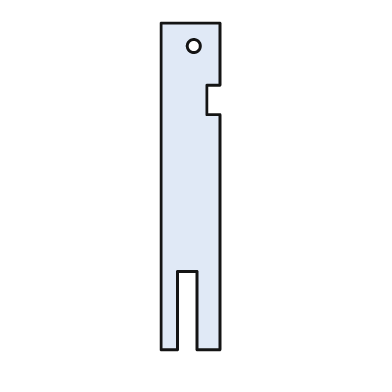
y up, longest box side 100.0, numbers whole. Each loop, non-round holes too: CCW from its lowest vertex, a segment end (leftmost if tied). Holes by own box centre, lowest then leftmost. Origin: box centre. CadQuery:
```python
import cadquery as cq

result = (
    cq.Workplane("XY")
    .moveTo(-9.0, -50.0)
    .lineTo(-4.0, -50.0)
    .lineTo(-4.0, -26.0)
    .lineTo(2.0, -26.0)
    .lineTo(2.0, -50.0)
    .lineTo(9.0, -50.0)
    .lineTo(9.0, 22.0)
    .lineTo(5.0, 22.0)
    .lineTo(5.0, 31.0)
    .lineTo(9.0, 31.0)
    .lineTo(9.0, 50.0)
    .lineTo(-9.0, 50.0)
    .close()
    .moveTo(1.0, 43.0)
    .circle(2.0)
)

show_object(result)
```